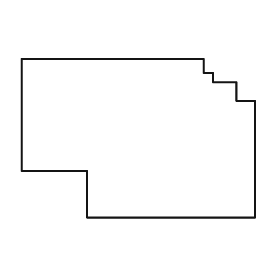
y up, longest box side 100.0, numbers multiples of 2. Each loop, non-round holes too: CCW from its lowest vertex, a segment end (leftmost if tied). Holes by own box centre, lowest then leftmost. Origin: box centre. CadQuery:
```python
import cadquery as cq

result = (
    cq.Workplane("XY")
    .moveTo(-22.0, -34.0)
    .lineTo(50.0, -34.0)
    .lineTo(50.0, 16.0)
    .lineTo(42.0, 16.0)
    .lineTo(42.0, 24.0)
    .lineTo(32.0, 24.0)
    .lineTo(32.0, 28.0)
    .lineTo(28.0, 28.0)
    .lineTo(28.0, 34.0)
    .lineTo(-50.0, 34.0)
    .lineTo(-50.0, -14.0)
    .lineTo(-22.0, -14.0)
    .close()
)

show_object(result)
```